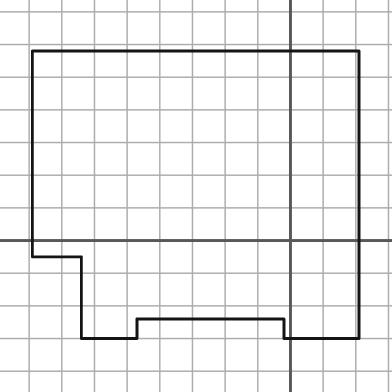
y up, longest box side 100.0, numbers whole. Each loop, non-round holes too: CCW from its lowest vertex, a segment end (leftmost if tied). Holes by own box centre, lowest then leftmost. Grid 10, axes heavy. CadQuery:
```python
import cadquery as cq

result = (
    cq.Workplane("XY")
    .moveTo(-64.0, -30.0)
    .lineTo(-47.0, -30.0)
    .lineTo(-47.0, -24.0)
    .lineTo(-2.0, -24.0)
    .lineTo(-2.0, -30.0)
    .lineTo(21.0, -30.0)
    .lineTo(21.0, 58.0)
    .lineTo(-79.0, 58.0)
    .lineTo(-79.0, -5.0)
    .lineTo(-64.0, -5.0)
    .close()
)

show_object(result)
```